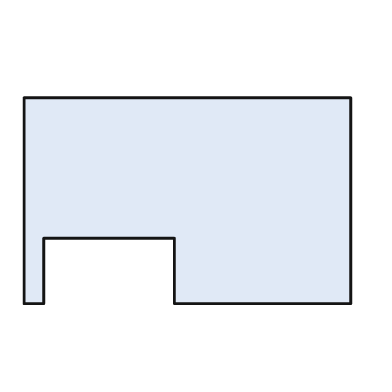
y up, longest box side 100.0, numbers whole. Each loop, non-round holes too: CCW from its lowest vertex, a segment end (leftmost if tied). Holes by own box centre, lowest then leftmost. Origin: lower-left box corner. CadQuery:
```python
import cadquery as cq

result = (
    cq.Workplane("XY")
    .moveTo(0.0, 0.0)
    .lineTo(6.0, 0.0)
    .lineTo(6.0, 20.0)
    .lineTo(46.0, 20.0)
    .lineTo(46.0, 0.0)
    .lineTo(100.0, 0.0)
    .lineTo(100.0, 63.0)
    .lineTo(0.0, 63.0)
    .close()
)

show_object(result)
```